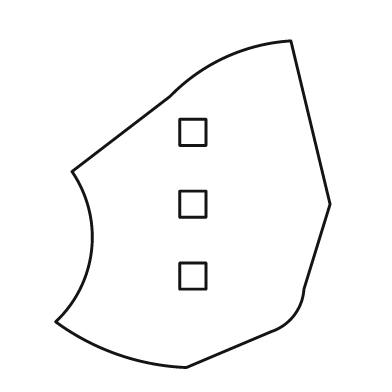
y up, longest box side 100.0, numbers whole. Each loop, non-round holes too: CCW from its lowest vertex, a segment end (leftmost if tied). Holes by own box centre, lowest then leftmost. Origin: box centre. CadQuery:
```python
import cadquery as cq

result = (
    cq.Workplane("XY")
    .moveTo(-2.0, -50.0)
    .lineTo(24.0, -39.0)
    .threePointArc((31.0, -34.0), (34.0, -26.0))
    .lineTo(42.0, 0.0)
    .lineTo(30.0, 50.0)
    .threePointArc((10.0, 45.0), (-7.0, 33.0))
    .lineTo(-37.0, 10.0)
    .threePointArc((-31.0, -14.0), (-42.0, -36.0))
    .threePointArc((-23.0, -46.0), (-2.0, -50.0))
    .close()
    .moveTo(-4.0, -26.0)
    .lineTo(4.0, -26.0)
    .lineTo(4.0, -18.0)
    .lineTo(-4.0, -18.0)
    .close()
    .moveTo(-4.0, -4.0)
    .lineTo(4.0, -4.0)
    .lineTo(4.0, 4.0)
    .lineTo(-4.0, 4.0)
    .close()
    .moveTo(-4.0, 18.0)
    .lineTo(4.0, 18.0)
    .lineTo(4.0, 26.0)
    .lineTo(-4.0, 26.0)
    .close()
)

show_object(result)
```